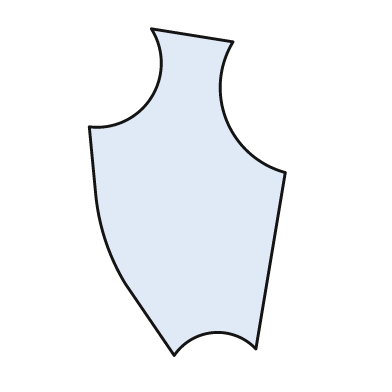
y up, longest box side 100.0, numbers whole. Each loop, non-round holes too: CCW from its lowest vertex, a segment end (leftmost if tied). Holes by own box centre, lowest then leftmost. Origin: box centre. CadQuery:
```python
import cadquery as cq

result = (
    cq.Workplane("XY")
    .moveTo(-4.0, -50.0)
    .threePointArc((8.0, -43.0), (21.0, -48.0))
    .lineTo(30.0, 6.0)
    .threePointArc((12.0, 22.0), (14.0, 46.0))
    .lineTo(-11.0, 50.0)
    .threePointArc((-11.0, 29.0), (-30.0, 20.0))
    .lineTo(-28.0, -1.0)
    .threePointArc((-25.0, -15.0), (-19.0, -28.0))
    .close()
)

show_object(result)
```